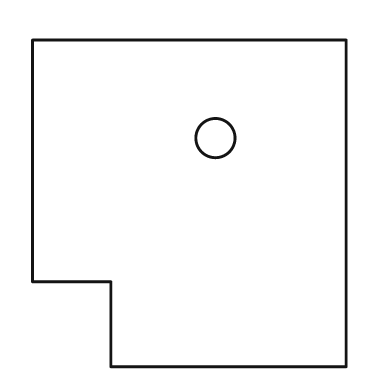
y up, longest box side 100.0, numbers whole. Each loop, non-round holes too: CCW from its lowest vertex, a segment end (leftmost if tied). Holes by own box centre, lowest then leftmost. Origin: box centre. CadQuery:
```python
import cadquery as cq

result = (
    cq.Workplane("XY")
    .moveTo(-24.0, -50.0)
    .lineTo(48.0, -50.0)
    .lineTo(48.0, 50.0)
    .lineTo(-48.0, 50.0)
    .lineTo(-48.0, -24.0)
    .lineTo(-24.0, -24.0)
    .close()
    .moveTo(8.0, 20.0)
    .circle(6.0)
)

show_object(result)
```